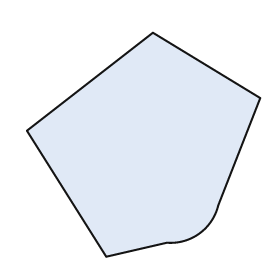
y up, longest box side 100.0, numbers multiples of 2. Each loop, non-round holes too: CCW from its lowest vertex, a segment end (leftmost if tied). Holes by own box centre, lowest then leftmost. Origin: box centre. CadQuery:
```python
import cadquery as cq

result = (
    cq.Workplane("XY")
    .moveTo(-16.0, -48.0)
    .lineTo(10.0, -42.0)
    .threePointArc((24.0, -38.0), (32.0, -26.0))
    .lineTo(50.0, 20.0)
    .lineTo(4.0, 48.0)
    .lineTo(-50.0, 6.0)
    .close()
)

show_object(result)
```